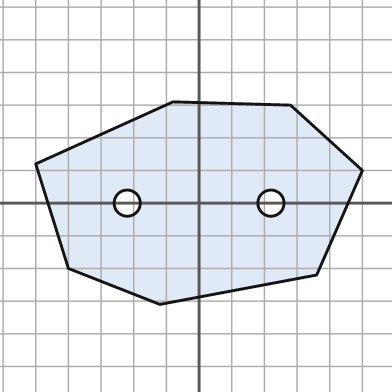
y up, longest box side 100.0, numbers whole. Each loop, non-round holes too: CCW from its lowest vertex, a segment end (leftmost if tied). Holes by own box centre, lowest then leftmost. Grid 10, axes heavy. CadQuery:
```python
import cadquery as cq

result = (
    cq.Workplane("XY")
    .moveTo(-12.0, -31.0)
    .lineTo(36.0, -22.0)
    .lineTo(50.0, 10.0)
    .lineTo(28.0, 30.0)
    .lineTo(-8.0, 31.0)
    .lineTo(-50.0, 12.0)
    .lineTo(-40.0, -20.0)
    .close()
    .moveTo(-22.0, 0.0)
    .circle(4.0)
    .moveTo(22.0, 0.0)
    .circle(4.0)
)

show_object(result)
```